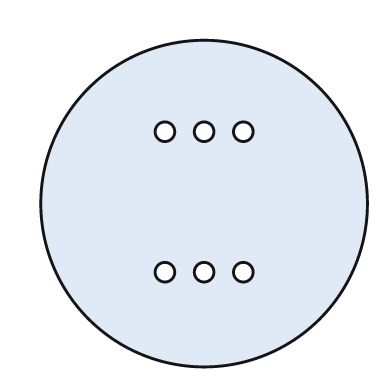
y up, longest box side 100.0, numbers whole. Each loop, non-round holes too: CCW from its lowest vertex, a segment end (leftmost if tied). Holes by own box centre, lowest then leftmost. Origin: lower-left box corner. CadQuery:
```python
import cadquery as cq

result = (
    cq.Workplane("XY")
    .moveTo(50.0, 50.0)
    .circle(50.0)
    .moveTo(38.0, 29.0)
    .circle(3.0)
    .moveTo(50.0, 29.0)
    .circle(3.0)
    .moveTo(62.0, 29.0)
    .circle(3.0)
    .moveTo(38.0, 72.0)
    .circle(3.0)
    .moveTo(50.0, 72.0)
    .circle(3.0)
    .moveTo(62.0, 72.0)
    .circle(3.0)
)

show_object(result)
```